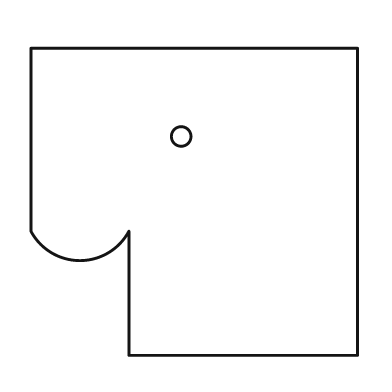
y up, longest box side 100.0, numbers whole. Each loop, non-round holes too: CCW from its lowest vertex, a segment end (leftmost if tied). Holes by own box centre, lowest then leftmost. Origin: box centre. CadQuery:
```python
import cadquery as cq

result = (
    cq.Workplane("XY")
    .moveTo(-20.0, -47.0)
    .lineTo(50.0, -47.0)
    .lineTo(50.0, 47.0)
    .lineTo(-50.0, 47.0)
    .lineTo(-50.0, -9.0)
    .threePointArc((-35.0, -18.0), (-20.0, -9.0))
    .close()
    .moveTo(-4.0, 20.0)
    .circle(3.0)
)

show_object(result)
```